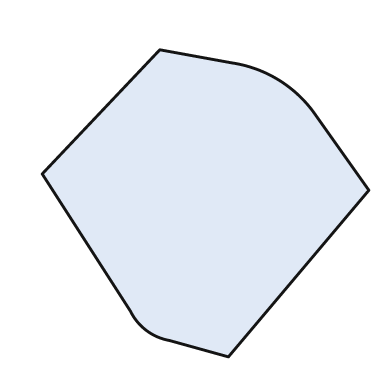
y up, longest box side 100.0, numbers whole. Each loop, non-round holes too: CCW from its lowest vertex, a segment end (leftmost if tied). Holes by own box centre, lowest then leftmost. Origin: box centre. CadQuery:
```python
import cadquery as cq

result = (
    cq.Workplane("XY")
    .moveTo(7.0, -47.0)
    .lineTo(50.0, 4.0)
    .lineTo(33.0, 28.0)
    .threePointArc((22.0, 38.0), (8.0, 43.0))
    .lineTo(-14.0, 47.0)
    .lineTo(-50.0, 9.0)
    .lineTo(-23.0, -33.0)
    .threePointArc((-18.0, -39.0), (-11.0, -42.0))
    .close()
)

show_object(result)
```